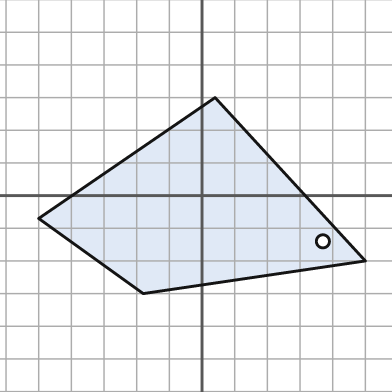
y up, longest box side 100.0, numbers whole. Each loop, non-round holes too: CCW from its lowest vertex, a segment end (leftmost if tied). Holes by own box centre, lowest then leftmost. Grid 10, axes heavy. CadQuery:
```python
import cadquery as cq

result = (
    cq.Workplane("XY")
    .moveTo(-18.0, -30.0)
    .lineTo(50.0, -20.0)
    .lineTo(4.0, 30.0)
    .lineTo(-50.0, -7.0)
    .close()
    .moveTo(37.0, -14.0)
    .circle(2.0)
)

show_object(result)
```